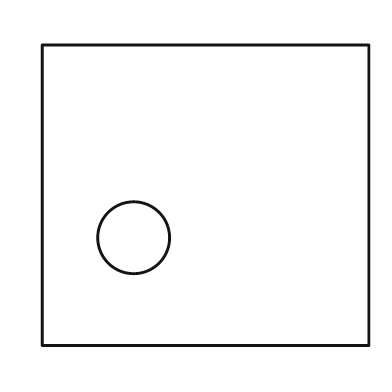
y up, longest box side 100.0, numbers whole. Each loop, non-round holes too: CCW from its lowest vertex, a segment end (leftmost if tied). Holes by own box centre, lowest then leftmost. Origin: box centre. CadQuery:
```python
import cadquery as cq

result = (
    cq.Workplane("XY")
    .moveTo(-50.0, -46.0)
    .lineTo(50.0, -46.0)
    .lineTo(50.0, 46.0)
    .lineTo(-50.0, 46.0)
    .close()
    .moveTo(-22.0, -13.0)
    .circle(11.0)
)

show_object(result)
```